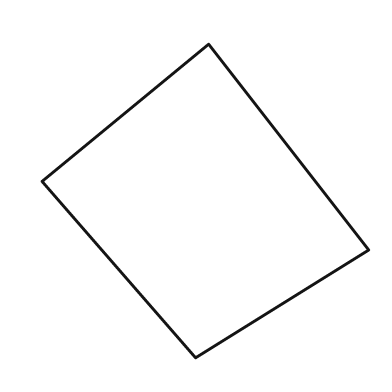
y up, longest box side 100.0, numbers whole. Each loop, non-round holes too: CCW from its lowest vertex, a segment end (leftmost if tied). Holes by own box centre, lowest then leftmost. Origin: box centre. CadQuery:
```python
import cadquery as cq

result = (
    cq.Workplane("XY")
    .moveTo(-3.0, -48.0)
    .lineTo(50.0, -15.0)
    .lineTo(1.0, 48.0)
    .lineTo(-50.0, 6.0)
    .close()
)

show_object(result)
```